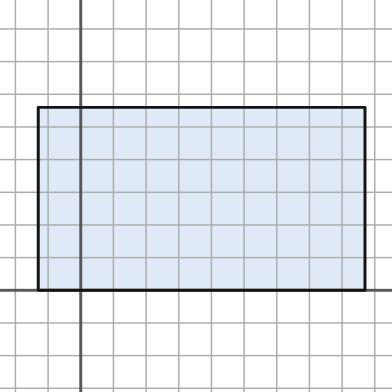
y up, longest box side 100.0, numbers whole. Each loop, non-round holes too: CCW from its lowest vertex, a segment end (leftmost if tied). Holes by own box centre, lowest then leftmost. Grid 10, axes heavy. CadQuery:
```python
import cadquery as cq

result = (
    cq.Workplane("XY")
    .moveTo(-13.0, 0.0)
    .lineTo(87.0, 0.0)
    .lineTo(87.0, 56.0)
    .lineTo(-13.0, 56.0)
    .close()
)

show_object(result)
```